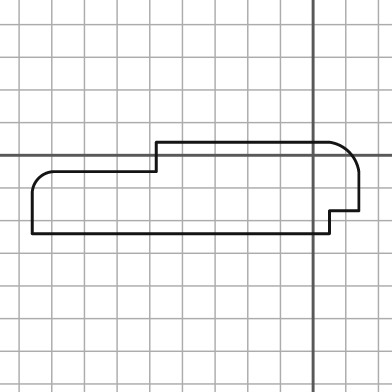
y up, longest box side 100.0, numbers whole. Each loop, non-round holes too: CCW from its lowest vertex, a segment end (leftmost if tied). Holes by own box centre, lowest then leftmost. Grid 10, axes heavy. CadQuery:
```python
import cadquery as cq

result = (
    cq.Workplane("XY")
    .moveTo(-86.0, -24.0)
    .lineTo(5.0, -24.0)
    .lineTo(5.0, -17.0)
    .lineTo(14.0, -17.0)
    .lineTo(14.0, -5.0)
    .threePointArc((11.0, 1.0), (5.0, 4.0))
    .lineTo(-48.0, 4.0)
    .lineTo(-48.0, -5.0)
    .lineTo(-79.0, -5.0)
    .threePointArc((-84.0, -7.0), (-86.0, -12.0))
    .close()
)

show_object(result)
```